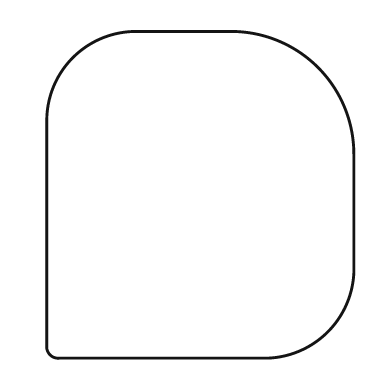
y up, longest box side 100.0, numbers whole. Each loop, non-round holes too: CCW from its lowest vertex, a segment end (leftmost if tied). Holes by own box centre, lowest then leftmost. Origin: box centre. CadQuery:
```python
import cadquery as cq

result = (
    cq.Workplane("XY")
    .moveTo(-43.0, -50.0)
    .lineTo(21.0, -50.0)
    .threePointArc((39.0, -42.0), (47.0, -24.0))
    .lineTo(47.0, 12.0)
    .threePointArc((36.0, 39.0), (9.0, 50.0))
    .lineTo(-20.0, 50.0)
    .threePointArc((-39.0, 42.0), (-47.0, 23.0))
    .lineTo(-47.0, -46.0)
    .threePointArc((-46.0, -49.0), (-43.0, -50.0))
    .close()
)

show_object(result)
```